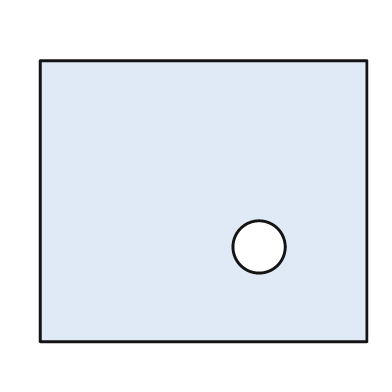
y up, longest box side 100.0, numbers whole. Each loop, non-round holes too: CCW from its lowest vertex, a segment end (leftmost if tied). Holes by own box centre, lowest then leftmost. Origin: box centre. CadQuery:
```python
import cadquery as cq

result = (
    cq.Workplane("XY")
    .moveTo(-50.0, -43.0)
    .lineTo(50.0, -43.0)
    .lineTo(50.0, 43.0)
    .lineTo(-50.0, 43.0)
    .close()
    .moveTo(17.0, -14.0)
    .circle(8.0)
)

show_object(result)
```